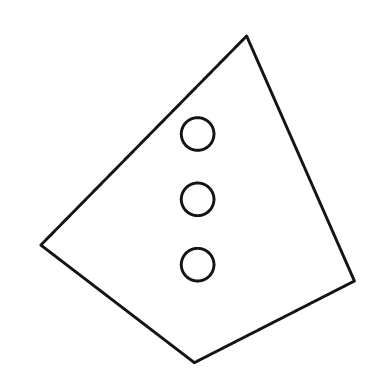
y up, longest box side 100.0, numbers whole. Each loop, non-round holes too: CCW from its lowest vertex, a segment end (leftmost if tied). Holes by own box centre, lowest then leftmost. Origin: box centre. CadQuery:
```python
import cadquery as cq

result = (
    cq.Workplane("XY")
    .moveTo(-1.0, -50.0)
    .lineTo(48.0, -25.0)
    .lineTo(15.0, 50.0)
    .lineTo(-48.0, -14.0)
    .close()
    .moveTo(0.0, -20.0)
    .circle(5.0)
    .moveTo(0.0, 0.0)
    .circle(5.0)
    .moveTo(0.0, 20.0)
    .circle(5.0)
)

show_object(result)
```